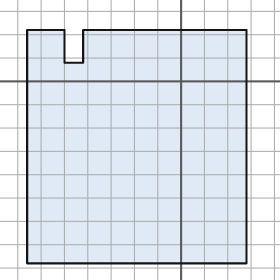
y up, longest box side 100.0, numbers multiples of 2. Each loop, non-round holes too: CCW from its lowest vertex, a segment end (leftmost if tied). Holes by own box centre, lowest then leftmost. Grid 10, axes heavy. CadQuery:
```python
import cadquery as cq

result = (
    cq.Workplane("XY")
    .moveTo(-66.0, -78.0)
    .lineTo(28.0, -78.0)
    .lineTo(28.0, 22.0)
    .lineTo(-42.0, 22.0)
    .lineTo(-42.0, 8.0)
    .lineTo(-50.0, 8.0)
    .lineTo(-50.0, 22.0)
    .lineTo(-66.0, 22.0)
    .close()
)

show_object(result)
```